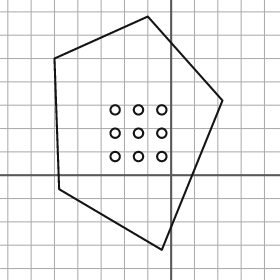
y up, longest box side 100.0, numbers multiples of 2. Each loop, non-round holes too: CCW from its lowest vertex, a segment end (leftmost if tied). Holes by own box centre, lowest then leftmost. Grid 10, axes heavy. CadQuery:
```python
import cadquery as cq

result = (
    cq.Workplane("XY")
    .moveTo(-4.0, -32.0)
    .lineTo(22.0, 32.0)
    .lineTo(-10.0, 68.0)
    .lineTo(-50.0, 50.0)
    .lineTo(-48.0, -6.0)
    .close()
    .moveTo(-24.0, 8.0)
    .circle(2.0)
    .moveTo(-14.0, 8.0)
    .circle(2.0)
    .moveTo(-4.0, 8.0)
    .circle(2.0)
    .moveTo(-24.0, 18.0)
    .circle(2.0)
    .moveTo(-14.0, 18.0)
    .circle(2.0)
    .moveTo(-4.0, 18.0)
    .circle(2.0)
    .moveTo(-24.0, 28.0)
    .circle(2.0)
    .moveTo(-14.0, 28.0)
    .circle(2.0)
    .moveTo(-4.0, 28.0)
    .circle(2.0)
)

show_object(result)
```